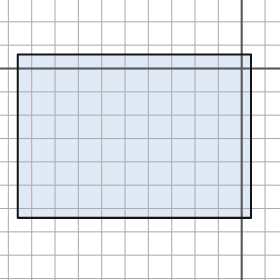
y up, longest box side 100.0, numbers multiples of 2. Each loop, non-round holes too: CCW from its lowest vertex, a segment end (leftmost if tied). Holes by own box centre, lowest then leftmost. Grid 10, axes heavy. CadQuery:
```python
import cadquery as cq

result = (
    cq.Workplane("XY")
    .moveTo(-96.0, -64.0)
    .lineTo(4.0, -64.0)
    .lineTo(4.0, 6.0)
    .lineTo(-96.0, 6.0)
    .close()
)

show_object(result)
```